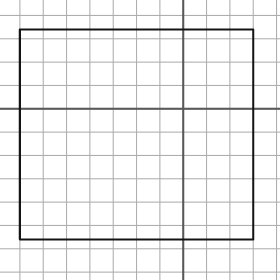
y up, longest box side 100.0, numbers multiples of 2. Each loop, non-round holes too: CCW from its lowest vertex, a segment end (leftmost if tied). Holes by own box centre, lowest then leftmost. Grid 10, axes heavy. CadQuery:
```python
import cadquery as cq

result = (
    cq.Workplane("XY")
    .moveTo(-70.0, -56.0)
    .lineTo(30.0, -56.0)
    .lineTo(30.0, 34.0)
    .lineTo(-70.0, 34.0)
    .close()
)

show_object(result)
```